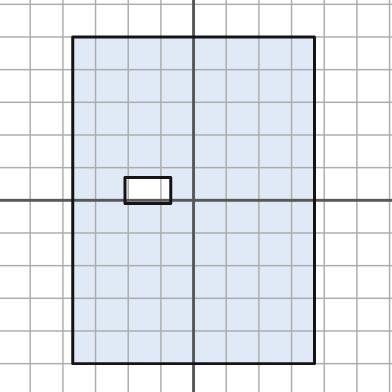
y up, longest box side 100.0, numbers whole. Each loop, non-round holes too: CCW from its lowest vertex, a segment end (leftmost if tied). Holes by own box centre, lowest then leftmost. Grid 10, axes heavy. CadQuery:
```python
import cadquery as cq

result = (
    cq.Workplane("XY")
    .moveTo(-37.0, -50.0)
    .lineTo(37.0, -50.0)
    .lineTo(37.0, 50.0)
    .lineTo(-37.0, 50.0)
    .close()
    .moveTo(-21.0, -1.0)
    .lineTo(-7.0, -1.0)
    .lineTo(-7.0, 7.0)
    .lineTo(-21.0, 7.0)
    .close()
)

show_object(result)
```